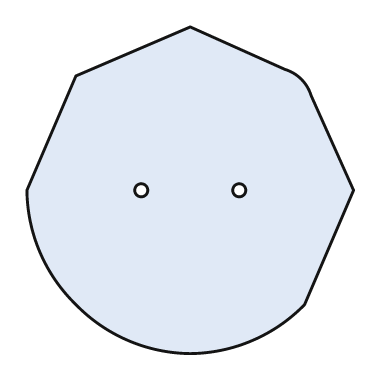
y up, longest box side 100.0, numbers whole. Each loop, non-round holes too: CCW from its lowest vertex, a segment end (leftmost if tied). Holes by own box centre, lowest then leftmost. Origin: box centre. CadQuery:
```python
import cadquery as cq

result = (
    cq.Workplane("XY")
    .moveTo(0.0, -50.0)
    .threePointArc((19.0, -46.0), (35.0, -35.0))
    .lineTo(50.0, 0.0)
    .lineTo(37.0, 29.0)
    .threePointArc((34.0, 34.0), (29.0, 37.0))
    .lineTo(0.0, 50.0)
    .lineTo(-35.0, 35.0)
    .lineTo(-50.0, 0.0)
    .threePointArc((-46.0, -19.0), (-35.0, -35.0))
    .threePointArc((-19.0, -46.0), (0.0, -50.0))
    .close()
    .moveTo(-15.0, 0.0)
    .circle(2.0)
    .moveTo(15.0, 0.0)
    .circle(2.0)
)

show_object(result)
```